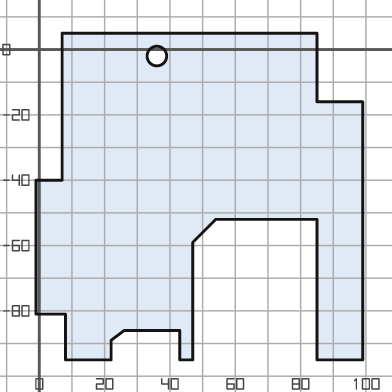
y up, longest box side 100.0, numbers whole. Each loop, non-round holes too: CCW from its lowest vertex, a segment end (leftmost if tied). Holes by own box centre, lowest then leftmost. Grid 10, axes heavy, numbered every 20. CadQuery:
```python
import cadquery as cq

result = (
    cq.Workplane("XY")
    .moveTo(8.0, -95.0)
    .lineTo(22.0, -95.0)
    .lineTo(22.0, -89.0)
    .lineTo(26.0, -86.0)
    .lineTo(43.0, -86.0)
    .lineTo(43.0, -95.0)
    .lineTo(47.0, -95.0)
    .lineTo(47.0, -59.0)
    .lineTo(54.0, -52.0)
    .lineTo(85.0, -52.0)
    .lineTo(85.0, -95.0)
    .lineTo(99.0, -95.0)
    .lineTo(99.0, -16.0)
    .lineTo(85.0, -16.0)
    .lineTo(85.0, 5.0)
    .lineTo(7.0, 5.0)
    .lineTo(7.0, -40.0)
    .lineTo(-1.0, -40.0)
    .lineTo(-1.0, -81.0)
    .lineTo(8.0, -81.0)
    .close()
    .moveTo(36.0, -2.0)
    .circle(3.0)
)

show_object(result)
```